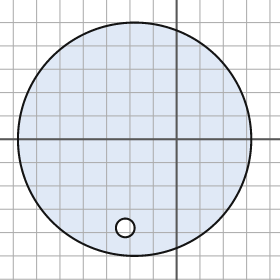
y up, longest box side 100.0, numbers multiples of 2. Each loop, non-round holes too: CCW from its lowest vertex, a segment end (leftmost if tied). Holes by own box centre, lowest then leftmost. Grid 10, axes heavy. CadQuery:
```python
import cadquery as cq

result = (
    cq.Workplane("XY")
    .moveTo(-18.0, 0.0)
    .circle(50.0)
    .moveTo(-22.0, -38.0)
    .circle(4.0)
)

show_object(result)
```